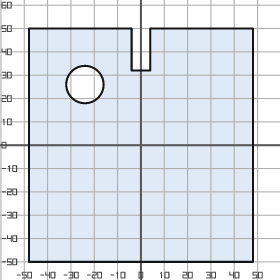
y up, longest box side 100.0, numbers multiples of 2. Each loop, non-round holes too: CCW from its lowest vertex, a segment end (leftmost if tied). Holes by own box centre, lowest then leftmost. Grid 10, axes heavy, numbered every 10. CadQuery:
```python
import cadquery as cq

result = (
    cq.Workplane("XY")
    .moveTo(-48.0, -50.0)
    .lineTo(48.0, -50.0)
    .lineTo(48.0, 50.0)
    .lineTo(4.0, 50.0)
    .lineTo(4.0, 32.0)
    .lineTo(-4.0, 32.0)
    .lineTo(-4.0, 50.0)
    .lineTo(-48.0, 50.0)
    .close()
    .moveTo(-24.0, 26.0)
    .circle(8.0)
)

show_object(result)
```